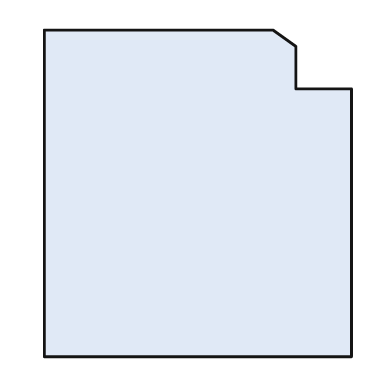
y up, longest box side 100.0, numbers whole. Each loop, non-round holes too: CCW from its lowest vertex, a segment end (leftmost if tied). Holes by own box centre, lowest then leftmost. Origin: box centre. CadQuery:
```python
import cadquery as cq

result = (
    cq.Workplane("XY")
    .moveTo(-47.0, -50.0)
    .lineTo(47.0, -50.0)
    .lineTo(47.0, 32.0)
    .lineTo(30.0, 32.0)
    .lineTo(30.0, 45.0)
    .lineTo(23.0, 50.0)
    .lineTo(-47.0, 50.0)
    .close()
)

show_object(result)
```